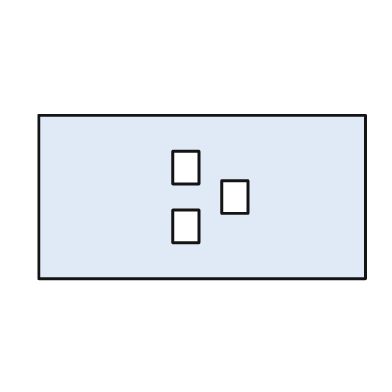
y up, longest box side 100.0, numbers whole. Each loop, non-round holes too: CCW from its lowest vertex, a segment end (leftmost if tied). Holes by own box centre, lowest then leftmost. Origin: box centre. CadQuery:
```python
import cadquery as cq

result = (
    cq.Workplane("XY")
    .moveTo(-50.0, -25.0)
    .lineTo(50.0, -25.0)
    .lineTo(50.0, 25.0)
    .lineTo(-50.0, 25.0)
    .close()
    .moveTo(-9.0, -14.0)
    .lineTo(-1.0, -14.0)
    .lineTo(-1.0, -4.0)
    .lineTo(-9.0, -4.0)
    .close()
    .moveTo(6.0, -5.0)
    .lineTo(14.0, -5.0)
    .lineTo(14.0, 5.0)
    .lineTo(6.0, 5.0)
    .close()
    .moveTo(-9.0, 4.0)
    .lineTo(-1.0, 4.0)
    .lineTo(-1.0, 14.0)
    .lineTo(-9.0, 14.0)
    .close()
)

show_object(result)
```